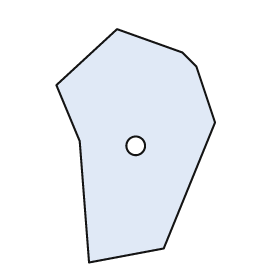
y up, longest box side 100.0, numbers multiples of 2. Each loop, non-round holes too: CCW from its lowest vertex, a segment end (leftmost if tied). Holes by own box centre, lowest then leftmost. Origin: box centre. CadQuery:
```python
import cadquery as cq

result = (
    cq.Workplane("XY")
    .moveTo(-20.0, -50.0)
    .lineTo(12.0, -44.0)
    .lineTo(34.0, 10.0)
    .lineTo(26.0, 34.0)
    .lineTo(20.0, 40.0)
    .lineTo(-8.0, 50.0)
    .lineTo(-34.0, 26.0)
    .lineTo(-24.0, 2.0)
    .close()
    .moveTo(0.0, 0.0)
    .circle(4.0)
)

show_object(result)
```